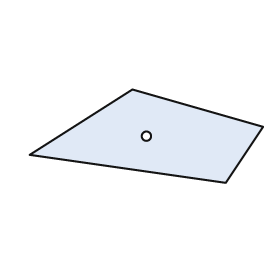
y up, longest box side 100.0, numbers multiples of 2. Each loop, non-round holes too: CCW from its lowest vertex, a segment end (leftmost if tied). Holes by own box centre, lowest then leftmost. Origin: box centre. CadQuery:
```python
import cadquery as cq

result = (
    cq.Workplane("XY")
    .moveTo(34.0, -20.0)
    .lineTo(50.0, 4.0)
    .lineTo(-6.0, 20.0)
    .lineTo(-50.0, -8.0)
    .close()
    .moveTo(0.0, 0.0)
    .circle(2.0)
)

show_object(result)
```